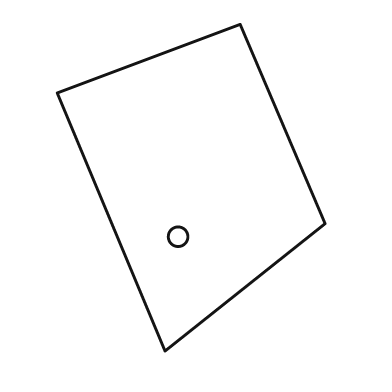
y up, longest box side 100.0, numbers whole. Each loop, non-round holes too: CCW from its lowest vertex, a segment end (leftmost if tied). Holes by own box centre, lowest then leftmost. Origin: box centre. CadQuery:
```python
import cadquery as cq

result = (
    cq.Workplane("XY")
    .moveTo(-8.0, -50.0)
    .lineTo(41.0, -11.0)
    .lineTo(15.0, 50.0)
    .lineTo(-41.0, 29.0)
    .close()
    .moveTo(-4.0, -15.0)
    .circle(3.0)
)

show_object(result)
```